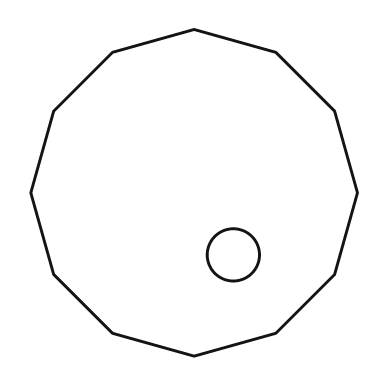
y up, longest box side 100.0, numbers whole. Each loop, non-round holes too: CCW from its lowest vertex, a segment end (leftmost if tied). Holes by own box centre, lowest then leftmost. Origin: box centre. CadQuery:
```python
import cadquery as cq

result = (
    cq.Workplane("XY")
    .moveTo(0.0, -50.0)
    .lineTo(25.0, -43.0)
    .lineTo(43.0, -25.0)
    .lineTo(50.0, 0.0)
    .lineTo(43.0, 25.0)
    .lineTo(25.0, 43.0)
    .lineTo(0.0, 50.0)
    .lineTo(-25.0, 43.0)
    .lineTo(-43.0, 25.0)
    .lineTo(-50.0, 0.0)
    .lineTo(-43.0, -25.0)
    .lineTo(-25.0, -43.0)
    .close()
    .moveTo(12.0, -19.0)
    .circle(8.0)
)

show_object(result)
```